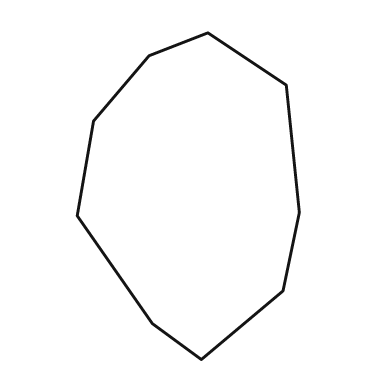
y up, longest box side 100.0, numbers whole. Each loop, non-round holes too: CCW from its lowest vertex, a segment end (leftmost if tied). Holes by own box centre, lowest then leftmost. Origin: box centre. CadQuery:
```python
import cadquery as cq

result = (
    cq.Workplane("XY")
    .moveTo(4.0, -50.0)
    .lineTo(29.0, -29.0)
    .lineTo(34.0, -5.0)
    .lineTo(30.0, 34.0)
    .lineTo(6.0, 50.0)
    .lineTo(-12.0, 43.0)
    .lineTo(-29.0, 23.0)
    .lineTo(-34.0, -6.0)
    .lineTo(-11.0, -39.0)
    .close()
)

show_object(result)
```